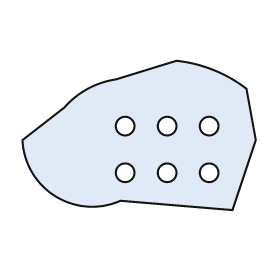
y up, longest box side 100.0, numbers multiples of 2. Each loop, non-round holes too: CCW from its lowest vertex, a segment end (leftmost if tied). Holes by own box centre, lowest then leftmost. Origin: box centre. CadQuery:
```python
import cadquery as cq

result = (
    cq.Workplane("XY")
    .moveTo(40.0, -32.0)
    .lineTo(50.0, -2.0)
    .lineTo(46.0, 20.0)
    .threePointArc((32.0, 28.0), (16.0, 32.0))
    .lineTo(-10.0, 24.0)
    .threePointArc((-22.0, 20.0), (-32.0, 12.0))
    .lineTo(-50.0, -2.0)
    .threePointArc((-36.0, -26.0), (-8.0, -28.0))
    .close()
    .moveTo(-6.0, -16.0)
    .circle(4.0)
    .moveTo(12.0, -16.0)
    .circle(4.0)
    .moveTo(30.0, -16.0)
    .circle(4.0)
    .moveTo(-6.0, 4.0)
    .circle(4.0)
    .moveTo(12.0, 4.0)
    .circle(4.0)
    .moveTo(30.0, 4.0)
    .circle(4.0)
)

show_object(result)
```